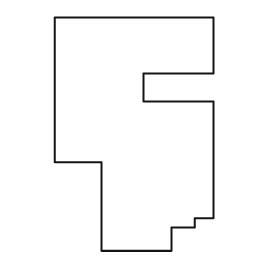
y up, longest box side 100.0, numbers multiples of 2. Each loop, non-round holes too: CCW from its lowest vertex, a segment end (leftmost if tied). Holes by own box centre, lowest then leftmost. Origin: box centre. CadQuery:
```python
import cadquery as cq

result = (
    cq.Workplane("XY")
    .moveTo(-14.0, -50.0)
    .lineTo(16.0, -50.0)
    .lineTo(16.0, -40.0)
    .lineTo(26.0, -40.0)
    .lineTo(26.0, -36.0)
    .lineTo(34.0, -36.0)
    .lineTo(34.0, 14.0)
    .lineTo(4.0, 14.0)
    .lineTo(4.0, 26.0)
    .lineTo(34.0, 26.0)
    .lineTo(34.0, 50.0)
    .lineTo(-34.0, 50.0)
    .lineTo(-34.0, -12.0)
    .lineTo(-14.0, -12.0)
    .close()
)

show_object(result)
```